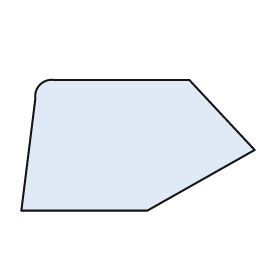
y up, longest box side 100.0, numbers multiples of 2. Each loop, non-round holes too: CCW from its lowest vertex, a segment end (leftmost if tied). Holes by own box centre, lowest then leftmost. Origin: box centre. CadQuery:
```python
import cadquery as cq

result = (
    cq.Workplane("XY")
    .moveTo(-50.0, -28.0)
    .lineTo(4.0, -28.0)
    .lineTo(50.0, -2.0)
    .lineTo(22.0, 28.0)
    .lineTo(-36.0, 28.0)
    .threePointArc((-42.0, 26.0), (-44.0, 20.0))
    .close()
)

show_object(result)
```